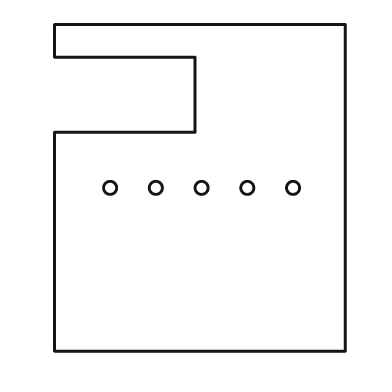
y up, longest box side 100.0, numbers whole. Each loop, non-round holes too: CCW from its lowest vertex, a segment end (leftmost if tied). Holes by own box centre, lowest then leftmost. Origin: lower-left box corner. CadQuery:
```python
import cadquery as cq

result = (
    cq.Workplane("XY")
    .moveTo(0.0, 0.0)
    .lineTo(89.0, 0.0)
    .lineTo(89.0, 100.0)
    .lineTo(0.0, 100.0)
    .lineTo(0.0, 90.0)
    .lineTo(43.0, 90.0)
    .lineTo(43.0, 67.0)
    .lineTo(0.0, 67.0)
    .close()
    .moveTo(17.0, 50.0)
    .circle(2.0)
    .moveTo(31.0, 50.0)
    .circle(2.0)
    .moveTo(45.0, 50.0)
    .circle(2.0)
    .moveTo(59.0, 50.0)
    .circle(2.0)
    .moveTo(73.0, 50.0)
    .circle(2.0)
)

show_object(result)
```